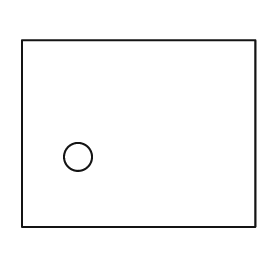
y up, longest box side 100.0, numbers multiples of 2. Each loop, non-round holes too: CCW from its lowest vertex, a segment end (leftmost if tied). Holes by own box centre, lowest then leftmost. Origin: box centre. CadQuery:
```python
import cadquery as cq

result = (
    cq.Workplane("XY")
    .moveTo(-50.0, -40.0)
    .lineTo(50.0, -40.0)
    .lineTo(50.0, 40.0)
    .lineTo(-50.0, 40.0)
    .close()
    .moveTo(-26.0, -10.0)
    .circle(6.0)
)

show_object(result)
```